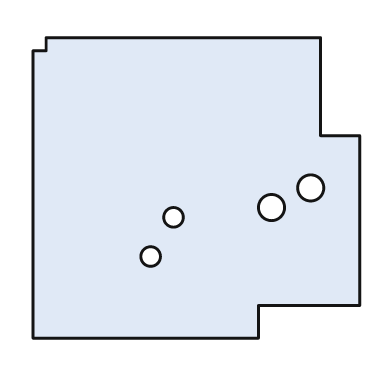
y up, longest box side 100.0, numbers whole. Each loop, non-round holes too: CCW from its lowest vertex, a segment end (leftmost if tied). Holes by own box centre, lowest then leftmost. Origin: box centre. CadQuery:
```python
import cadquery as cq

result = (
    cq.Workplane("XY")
    .moveTo(-50.0, -46.0)
    .lineTo(19.0, -46.0)
    .lineTo(19.0, -36.0)
    .lineTo(50.0, -36.0)
    .lineTo(50.0, 16.0)
    .lineTo(38.0, 16.0)
    .lineTo(38.0, 46.0)
    .lineTo(-46.0, 46.0)
    .lineTo(-46.0, 42.0)
    .lineTo(-50.0, 42.0)
    .close()
    .moveTo(-14.0, -21.0)
    .circle(3.0)
    .moveTo(-7.0, -9.0)
    .circle(3.0)
    .moveTo(23.0, -6.0)
    .circle(4.0)
    .moveTo(35.0, 0.0)
    .circle(4.0)
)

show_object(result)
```